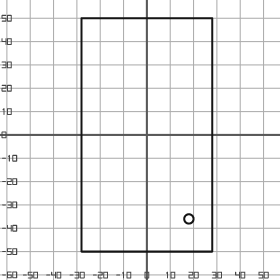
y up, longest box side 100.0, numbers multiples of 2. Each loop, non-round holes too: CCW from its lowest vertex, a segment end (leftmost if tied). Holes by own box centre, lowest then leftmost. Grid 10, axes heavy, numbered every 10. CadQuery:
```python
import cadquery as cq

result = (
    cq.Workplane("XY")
    .moveTo(-28.0, -50.0)
    .lineTo(28.0, -50.0)
    .lineTo(28.0, 50.0)
    .lineTo(-28.0, 50.0)
    .close()
    .moveTo(18.0, -36.0)
    .circle(2.0)
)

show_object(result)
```